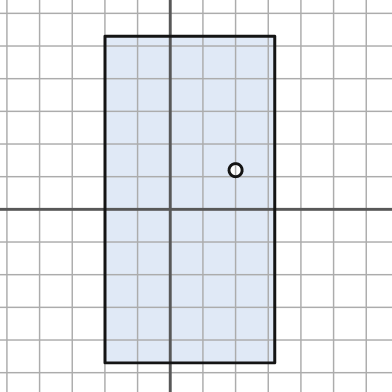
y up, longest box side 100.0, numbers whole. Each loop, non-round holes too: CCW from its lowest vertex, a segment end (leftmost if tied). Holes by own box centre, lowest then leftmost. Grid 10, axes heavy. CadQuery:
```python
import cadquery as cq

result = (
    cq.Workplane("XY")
    .moveTo(-20.0, -47.0)
    .lineTo(32.0, -47.0)
    .lineTo(32.0, 53.0)
    .lineTo(-20.0, 53.0)
    .close()
    .moveTo(20.0, 12.0)
    .circle(2.0)
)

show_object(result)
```